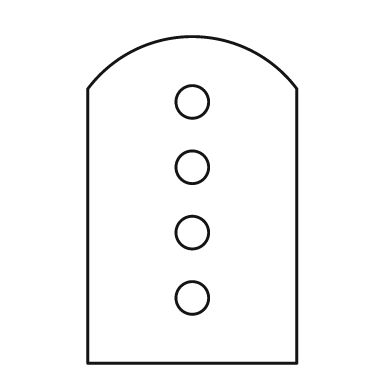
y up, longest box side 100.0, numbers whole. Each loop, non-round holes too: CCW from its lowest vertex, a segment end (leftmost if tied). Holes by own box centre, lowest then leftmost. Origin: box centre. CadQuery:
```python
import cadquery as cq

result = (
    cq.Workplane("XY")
    .moveTo(-32.0, -50.0)
    .lineTo(32.0, -50.0)
    .lineTo(32.0, 34.0)
    .threePointArc((0.0, 50.0), (-32.0, 34.0))
    .close()
    .moveTo(0.0, -30.0)
    .circle(5.0)
    .moveTo(0.0, -10.0)
    .circle(5.0)
    .moveTo(0.0, 10.0)
    .circle(5.0)
    .moveTo(0.0, 30.0)
    .circle(5.0)
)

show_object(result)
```